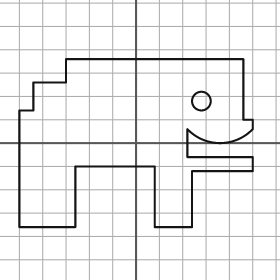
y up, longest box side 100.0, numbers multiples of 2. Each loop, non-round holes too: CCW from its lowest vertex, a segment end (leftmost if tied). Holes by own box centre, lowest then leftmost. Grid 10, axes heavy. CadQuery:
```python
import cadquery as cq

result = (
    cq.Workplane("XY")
    .moveTo(-50.0, -36.0)
    .lineTo(-26.0, -36.0)
    .lineTo(-26.0, -10.0)
    .lineTo(8.0, -10.0)
    .lineTo(8.0, -36.0)
    .lineTo(24.0, -36.0)
    .lineTo(24.0, -12.0)
    .lineTo(50.0, -12.0)
    .lineTo(50.0, -6.0)
    .lineTo(22.0, -6.0)
    .lineTo(22.0, 6.0)
    .threePointArc((36.0, 0.0), (50.0, 6.0))
    .lineTo(50.0, 10.0)
    .lineTo(46.0, 10.0)
    .lineTo(46.0, 36.0)
    .lineTo(-30.0, 36.0)
    .lineTo(-30.0, 26.0)
    .lineTo(-44.0, 26.0)
    .lineTo(-44.0, 14.0)
    .lineTo(-50.0, 14.0)
    .close()
    .moveTo(28.0, 18.0)
    .circle(4.0)
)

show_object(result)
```